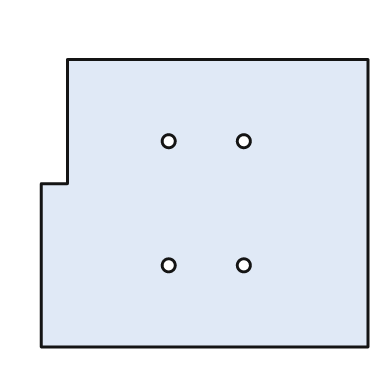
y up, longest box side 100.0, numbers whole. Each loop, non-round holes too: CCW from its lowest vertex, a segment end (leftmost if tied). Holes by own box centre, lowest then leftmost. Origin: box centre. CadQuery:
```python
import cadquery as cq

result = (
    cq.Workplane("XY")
    .moveTo(-50.0, -44.0)
    .lineTo(50.0, -44.0)
    .lineTo(50.0, 44.0)
    .lineTo(-42.0, 44.0)
    .lineTo(-42.0, 6.0)
    .lineTo(-50.0, 6.0)
    .close()
    .moveTo(-11.0, -19.0)
    .circle(2.0)
    .moveTo(12.0, -19.0)
    .circle(2.0)
    .moveTo(-11.0, 19.0)
    .circle(2.0)
    .moveTo(12.0, 19.0)
    .circle(2.0)
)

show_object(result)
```